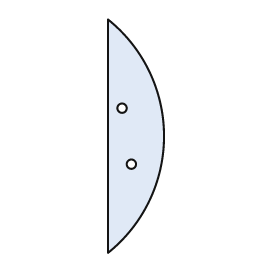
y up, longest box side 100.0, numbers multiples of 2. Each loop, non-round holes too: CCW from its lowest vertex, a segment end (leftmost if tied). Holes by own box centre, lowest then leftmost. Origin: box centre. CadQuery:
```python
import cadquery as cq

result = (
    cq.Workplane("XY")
    .moveTo(-12.0, -50.0)
    .threePointArc((12.0, 0.0), (-12.0, 50.0))
    .close()
    .moveTo(-2.0, -12.0)
    .circle(2.0)
    .moveTo(-6.0, 12.0)
    .circle(2.0)
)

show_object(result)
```